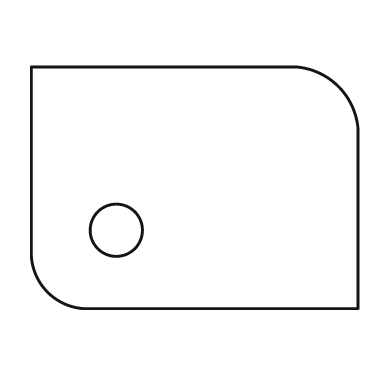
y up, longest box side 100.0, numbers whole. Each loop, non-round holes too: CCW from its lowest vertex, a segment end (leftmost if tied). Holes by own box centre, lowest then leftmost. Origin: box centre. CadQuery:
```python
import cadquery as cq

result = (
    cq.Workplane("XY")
    .moveTo(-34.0, -37.0)
    .lineTo(50.0, -37.0)
    .lineTo(50.0, 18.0)
    .threePointArc((44.0, 31.0), (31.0, 37.0))
    .lineTo(-50.0, 37.0)
    .lineTo(-50.0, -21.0)
    .threePointArc((-45.0, -32.0), (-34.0, -37.0))
    .close()
    .moveTo(-24.0, -13.0)
    .circle(8.0)
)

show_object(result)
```